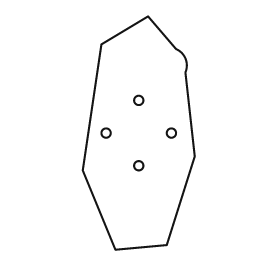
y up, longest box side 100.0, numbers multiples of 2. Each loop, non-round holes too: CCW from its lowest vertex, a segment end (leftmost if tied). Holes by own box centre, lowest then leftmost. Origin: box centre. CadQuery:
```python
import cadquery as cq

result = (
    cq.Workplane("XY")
    .moveTo(-10.0, -50.0)
    .lineTo(12.0, -48.0)
    .lineTo(24.0, -10.0)
    .lineTo(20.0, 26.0)
    .threePointArc((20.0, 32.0), (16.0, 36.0))
    .lineTo(4.0, 50.0)
    .lineTo(-16.0, 38.0)
    .lineTo(-24.0, -16.0)
    .close()
    .moveTo(0.0, -14.0)
    .circle(2.0)
    .moveTo(-14.0, 0.0)
    .circle(2.0)
    .moveTo(14.0, 0.0)
    .circle(2.0)
    .moveTo(0.0, 14.0)
    .circle(2.0)
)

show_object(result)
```